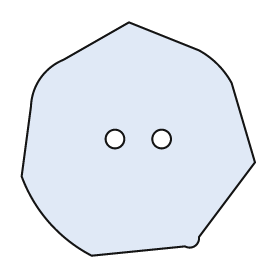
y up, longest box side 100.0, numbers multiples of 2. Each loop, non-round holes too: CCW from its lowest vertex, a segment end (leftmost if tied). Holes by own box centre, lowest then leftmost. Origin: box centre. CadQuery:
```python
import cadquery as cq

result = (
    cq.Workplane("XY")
    .moveTo(-20.0, -50.0)
    .lineTo(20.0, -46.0)
    .threePointArc((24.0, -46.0), (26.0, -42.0))
    .lineTo(50.0, -10.0)
    .lineTo(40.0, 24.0)
    .threePointArc((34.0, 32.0), (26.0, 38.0))
    .lineTo(-4.0, 50.0)
    .lineTo(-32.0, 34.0)
    .threePointArc((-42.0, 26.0), (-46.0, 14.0))
    .lineTo(-50.0, -16.0)
    .threePointArc((-38.0, -36.0), (-20.0, -50.0))
    .close()
    .moveTo(-10.0, 0.0)
    .circle(4.0)
    .moveTo(10.0, 0.0)
    .circle(4.0)
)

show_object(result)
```